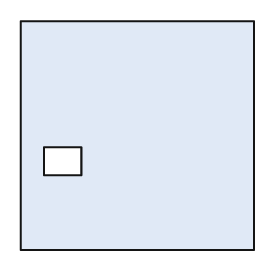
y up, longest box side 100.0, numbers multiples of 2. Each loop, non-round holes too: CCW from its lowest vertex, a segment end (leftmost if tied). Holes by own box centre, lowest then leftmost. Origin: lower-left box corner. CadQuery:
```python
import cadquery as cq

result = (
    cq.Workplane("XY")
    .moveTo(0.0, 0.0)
    .lineTo(100.0, 0.0)
    .lineTo(100.0, 98.0)
    .lineTo(0.0, 98.0)
    .close()
    .moveTo(10.0, 32.0)
    .lineTo(26.0, 32.0)
    .lineTo(26.0, 44.0)
    .lineTo(10.0, 44.0)
    .close()
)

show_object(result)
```